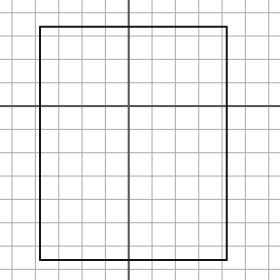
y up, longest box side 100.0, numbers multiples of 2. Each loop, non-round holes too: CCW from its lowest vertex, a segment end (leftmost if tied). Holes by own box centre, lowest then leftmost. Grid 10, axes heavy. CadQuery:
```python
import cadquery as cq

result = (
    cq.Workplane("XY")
    .moveTo(-38.0, -66.0)
    .lineTo(42.0, -66.0)
    .lineTo(42.0, 34.0)
    .lineTo(-38.0, 34.0)
    .close()
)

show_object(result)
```